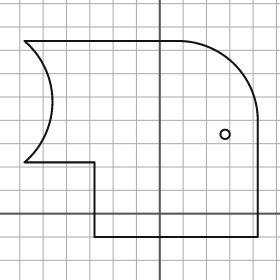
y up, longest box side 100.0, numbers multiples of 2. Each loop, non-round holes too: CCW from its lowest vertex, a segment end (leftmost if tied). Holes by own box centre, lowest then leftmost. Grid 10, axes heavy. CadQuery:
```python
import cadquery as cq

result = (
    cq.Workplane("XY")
    .moveTo(-28.0, -10.0)
    .lineTo(42.0, -10.0)
    .lineTo(42.0, 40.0)
    .threePointArc((32.0, 64.0), (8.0, 74.0))
    .lineTo(-58.0, 74.0)
    .threePointArc((-46.0, 48.0), (-58.0, 22.0))
    .lineTo(-28.0, 22.0)
    .close()
    .moveTo(28.0, 34.0)
    .circle(2.0)
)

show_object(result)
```